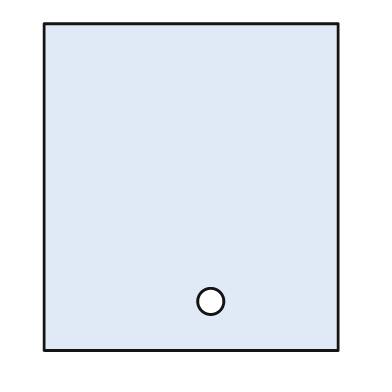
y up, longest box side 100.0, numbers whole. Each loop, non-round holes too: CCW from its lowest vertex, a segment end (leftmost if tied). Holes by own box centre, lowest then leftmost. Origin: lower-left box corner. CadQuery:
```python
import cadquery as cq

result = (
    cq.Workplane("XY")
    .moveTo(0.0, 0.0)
    .lineTo(90.0, 0.0)
    .lineTo(90.0, 100.0)
    .lineTo(0.0, 100.0)
    .close()
    .moveTo(51.0, 15.0)
    .circle(4.0)
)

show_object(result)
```